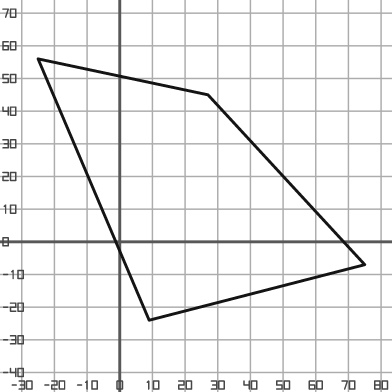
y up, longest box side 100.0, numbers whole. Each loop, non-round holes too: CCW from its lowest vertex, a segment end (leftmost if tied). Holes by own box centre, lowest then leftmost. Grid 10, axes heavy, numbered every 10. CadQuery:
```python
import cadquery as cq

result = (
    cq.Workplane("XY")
    .moveTo(9.0, -24.0)
    .lineTo(75.0, -7.0)
    .lineTo(27.0, 45.0)
    .lineTo(-25.0, 56.0)
    .close()
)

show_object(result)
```